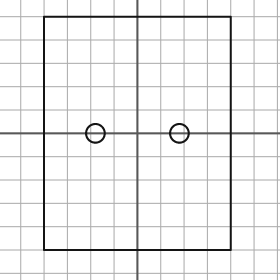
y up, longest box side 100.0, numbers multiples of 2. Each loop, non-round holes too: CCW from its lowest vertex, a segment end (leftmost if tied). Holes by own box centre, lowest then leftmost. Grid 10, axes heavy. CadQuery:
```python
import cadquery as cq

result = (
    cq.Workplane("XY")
    .moveTo(-40.0, -50.0)
    .lineTo(40.0, -50.0)
    .lineTo(40.0, 50.0)
    .lineTo(-40.0, 50.0)
    .close()
    .moveTo(-18.0, 0.0)
    .circle(4.0)
    .moveTo(18.0, 0.0)
    .circle(4.0)
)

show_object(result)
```